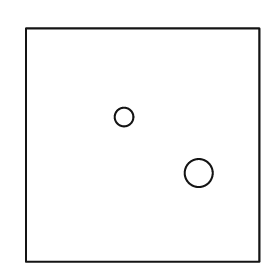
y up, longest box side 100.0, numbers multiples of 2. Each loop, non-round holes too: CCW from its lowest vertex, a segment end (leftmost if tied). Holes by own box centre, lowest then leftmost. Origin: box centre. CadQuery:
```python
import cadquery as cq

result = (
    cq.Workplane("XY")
    .moveTo(-50.0, -50.0)
    .lineTo(50.0, -50.0)
    .lineTo(50.0, 50.0)
    .lineTo(-50.0, 50.0)
    .close()
    .moveTo(24.0, -12.0)
    .circle(6.0)
    .moveTo(-8.0, 12.0)
    .circle(4.0)
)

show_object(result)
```